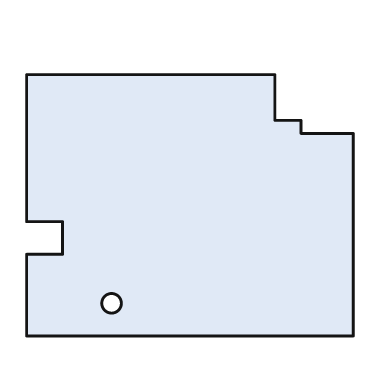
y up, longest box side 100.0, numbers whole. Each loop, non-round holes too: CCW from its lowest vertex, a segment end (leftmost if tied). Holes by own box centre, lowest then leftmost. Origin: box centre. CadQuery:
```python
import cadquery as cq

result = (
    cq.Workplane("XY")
    .moveTo(-50.0, -40.0)
    .lineTo(50.0, -40.0)
    .lineTo(50.0, 22.0)
    .lineTo(34.0, 22.0)
    .lineTo(34.0, 26.0)
    .lineTo(26.0, 26.0)
    .lineTo(26.0, 40.0)
    .lineTo(-50.0, 40.0)
    .lineTo(-50.0, -5.0)
    .lineTo(-39.0, -5.0)
    .lineTo(-39.0, -15.0)
    .lineTo(-50.0, -15.0)
    .close()
    .moveTo(-24.0, -30.0)
    .circle(3.0)
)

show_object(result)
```